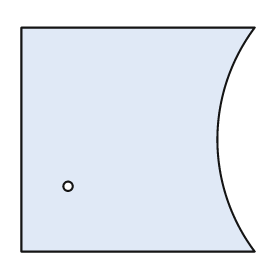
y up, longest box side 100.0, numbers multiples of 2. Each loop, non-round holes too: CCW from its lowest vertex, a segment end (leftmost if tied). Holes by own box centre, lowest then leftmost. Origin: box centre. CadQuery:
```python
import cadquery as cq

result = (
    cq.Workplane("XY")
    .moveTo(-50.0, -48.0)
    .lineTo(50.0, -48.0)
    .threePointArc((34.0, 0.0), (50.0, 48.0))
    .lineTo(-50.0, 48.0)
    .close()
    .moveTo(-30.0, -20.0)
    .circle(2.0)
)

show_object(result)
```